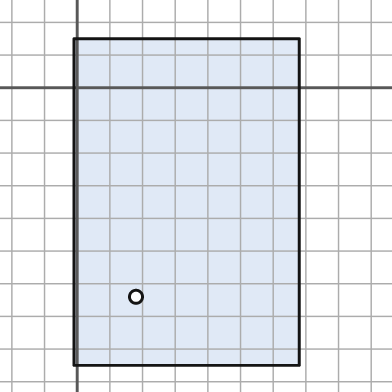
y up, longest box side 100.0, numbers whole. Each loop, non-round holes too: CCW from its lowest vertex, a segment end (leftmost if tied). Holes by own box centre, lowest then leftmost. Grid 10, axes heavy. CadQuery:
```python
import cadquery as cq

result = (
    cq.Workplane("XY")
    .moveTo(-1.0, -85.0)
    .lineTo(68.0, -85.0)
    .lineTo(68.0, 15.0)
    .lineTo(-1.0, 15.0)
    .close()
    .moveTo(18.0, -64.0)
    .circle(2.0)
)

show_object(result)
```